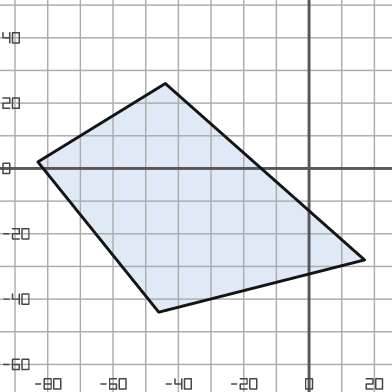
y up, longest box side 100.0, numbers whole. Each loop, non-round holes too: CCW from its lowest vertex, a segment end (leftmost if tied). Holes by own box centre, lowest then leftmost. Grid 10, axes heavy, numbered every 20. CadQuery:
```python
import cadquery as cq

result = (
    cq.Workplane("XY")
    .moveTo(-46.0, -44.0)
    .lineTo(17.0, -28.0)
    .lineTo(-44.0, 26.0)
    .lineTo(-83.0, 2.0)
    .close()
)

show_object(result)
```